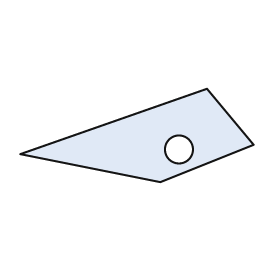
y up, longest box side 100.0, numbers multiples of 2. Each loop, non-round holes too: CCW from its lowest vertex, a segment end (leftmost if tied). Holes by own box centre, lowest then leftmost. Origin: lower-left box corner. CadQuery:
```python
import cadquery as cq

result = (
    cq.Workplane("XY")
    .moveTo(60.0, 0.0)
    .lineTo(100.0, 16.0)
    .lineTo(80.0, 40.0)
    .lineTo(0.0, 12.0)
    .close()
    .moveTo(68.0, 14.0)
    .circle(6.0)
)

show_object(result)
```